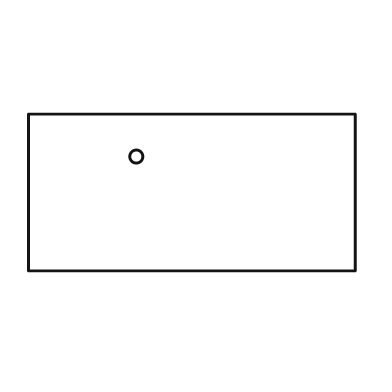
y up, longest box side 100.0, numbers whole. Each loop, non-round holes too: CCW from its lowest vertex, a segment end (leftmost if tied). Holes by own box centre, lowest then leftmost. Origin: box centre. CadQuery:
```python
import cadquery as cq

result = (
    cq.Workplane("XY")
    .moveTo(-50.0, -24.0)
    .lineTo(50.0, -24.0)
    .lineTo(50.0, 24.0)
    .lineTo(-50.0, 24.0)
    .close()
    .moveTo(-17.0, 11.0)
    .circle(2.0)
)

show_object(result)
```